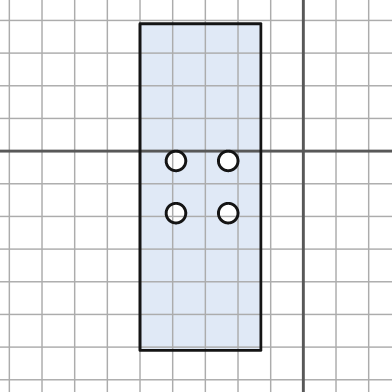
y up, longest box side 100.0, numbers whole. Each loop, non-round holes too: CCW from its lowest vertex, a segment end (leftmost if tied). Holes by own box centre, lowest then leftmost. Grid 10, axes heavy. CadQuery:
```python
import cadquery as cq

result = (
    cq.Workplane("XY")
    .moveTo(-50.0, -61.0)
    .lineTo(-13.0, -61.0)
    .lineTo(-13.0, 39.0)
    .lineTo(-50.0, 39.0)
    .close()
    .moveTo(-39.0, -19.0)
    .circle(3.0)
    .moveTo(-23.0, -19.0)
    .circle(3.0)
    .moveTo(-39.0, -3.0)
    .circle(3.0)
    .moveTo(-23.0, -3.0)
    .circle(3.0)
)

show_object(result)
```